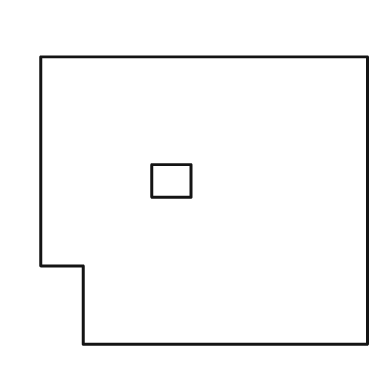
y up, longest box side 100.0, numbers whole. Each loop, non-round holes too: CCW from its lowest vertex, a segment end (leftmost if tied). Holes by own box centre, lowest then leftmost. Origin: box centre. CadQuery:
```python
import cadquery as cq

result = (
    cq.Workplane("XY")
    .moveTo(-37.0, -44.0)
    .lineTo(50.0, -44.0)
    .lineTo(50.0, 44.0)
    .lineTo(-50.0, 44.0)
    .lineTo(-50.0, -20.0)
    .lineTo(-37.0, -20.0)
    .close()
    .moveTo(-16.0, 1.0)
    .lineTo(-4.0, 1.0)
    .lineTo(-4.0, 11.0)
    .lineTo(-16.0, 11.0)
    .close()
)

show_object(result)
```